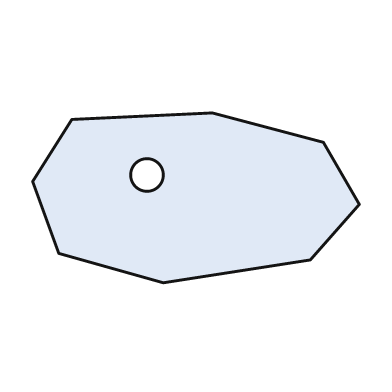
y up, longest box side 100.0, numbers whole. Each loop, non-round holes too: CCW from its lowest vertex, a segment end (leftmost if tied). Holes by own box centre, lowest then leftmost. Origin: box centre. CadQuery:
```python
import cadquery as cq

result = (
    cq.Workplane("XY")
    .moveTo(-10.0, -26.0)
    .lineTo(35.0, -19.0)
    .lineTo(50.0, -2.0)
    .lineTo(39.0, 17.0)
    .lineTo(5.0, 26.0)
    .lineTo(-38.0, 24.0)
    .lineTo(-50.0, 5.0)
    .lineTo(-42.0, -17.0)
    .close()
    .moveTo(-15.0, 7.0)
    .circle(5.0)
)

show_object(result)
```